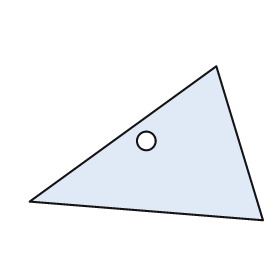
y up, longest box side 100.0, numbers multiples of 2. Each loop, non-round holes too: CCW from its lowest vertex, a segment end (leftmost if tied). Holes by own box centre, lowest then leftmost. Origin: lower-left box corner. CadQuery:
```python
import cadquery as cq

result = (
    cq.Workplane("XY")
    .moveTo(100.0, 0.0)
    .lineTo(80.0, 66.0)
    .lineTo(0.0, 8.0)
    .close()
    .moveTo(50.0, 34.0)
    .circle(4.0)
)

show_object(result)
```